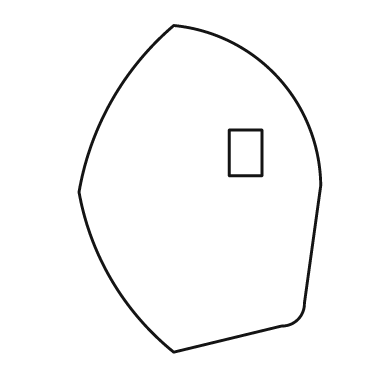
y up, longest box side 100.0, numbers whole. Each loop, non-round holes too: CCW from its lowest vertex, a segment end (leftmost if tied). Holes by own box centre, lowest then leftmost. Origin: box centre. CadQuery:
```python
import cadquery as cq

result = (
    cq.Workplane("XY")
    .moveTo(-8.0, -50.0)
    .lineTo(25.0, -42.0)
    .threePointArc((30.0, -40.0), (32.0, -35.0))
    .lineTo(37.0, 1.0)
    .threePointArc((24.0, 34.0), (-8.0, 50.0))
    .threePointArc((-27.0, 27.0), (-37.0, -1.0))
    .threePointArc((-27.0, -28.0), (-8.0, -50.0))
    .close()
    .moveTo(9.0, 4.0)
    .lineTo(19.0, 4.0)
    .lineTo(19.0, 18.0)
    .lineTo(9.0, 18.0)
    .close()
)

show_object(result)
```